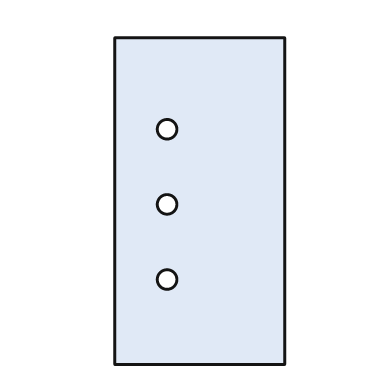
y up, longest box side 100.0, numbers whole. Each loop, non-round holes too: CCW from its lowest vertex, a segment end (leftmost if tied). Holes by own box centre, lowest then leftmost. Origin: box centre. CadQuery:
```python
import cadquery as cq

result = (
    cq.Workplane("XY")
    .moveTo(-26.0, -50.0)
    .lineTo(26.0, -50.0)
    .lineTo(26.0, 50.0)
    .lineTo(-26.0, 50.0)
    .close()
    .moveTo(-10.0, -24.0)
    .circle(3.0)
    .moveTo(-10.0, -1.0)
    .circle(3.0)
    .moveTo(-10.0, 22.0)
    .circle(3.0)
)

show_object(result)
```